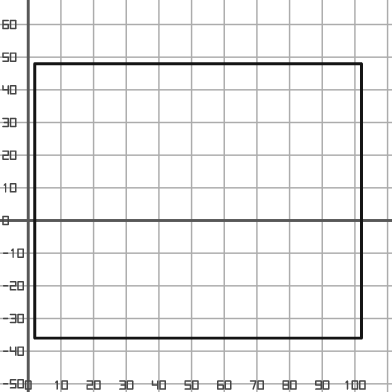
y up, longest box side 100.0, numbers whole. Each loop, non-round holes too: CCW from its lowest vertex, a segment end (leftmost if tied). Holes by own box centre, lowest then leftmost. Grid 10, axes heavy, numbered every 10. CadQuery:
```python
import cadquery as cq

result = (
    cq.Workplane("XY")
    .moveTo(2.0, -36.0)
    .lineTo(102.0, -36.0)
    .lineTo(102.0, 48.0)
    .lineTo(2.0, 48.0)
    .close()
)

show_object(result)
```